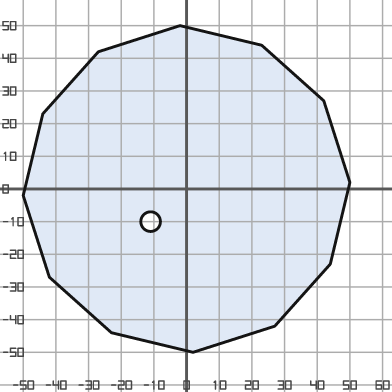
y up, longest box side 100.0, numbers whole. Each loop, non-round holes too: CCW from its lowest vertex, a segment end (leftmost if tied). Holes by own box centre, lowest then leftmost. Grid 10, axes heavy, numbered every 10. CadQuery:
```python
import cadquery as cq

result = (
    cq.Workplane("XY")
    .moveTo(2.0, -50.0)
    .lineTo(27.0, -42.0)
    .lineTo(44.0, -23.0)
    .lineTo(50.0, 2.0)
    .lineTo(42.0, 27.0)
    .lineTo(23.0, 44.0)
    .lineTo(-2.0, 50.0)
    .lineTo(-27.0, 42.0)
    .lineTo(-44.0, 23.0)
    .lineTo(-50.0, -2.0)
    .lineTo(-42.0, -27.0)
    .lineTo(-23.0, -44.0)
    .close()
    .moveTo(-11.0, -10.0)
    .circle(3.0)
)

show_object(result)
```